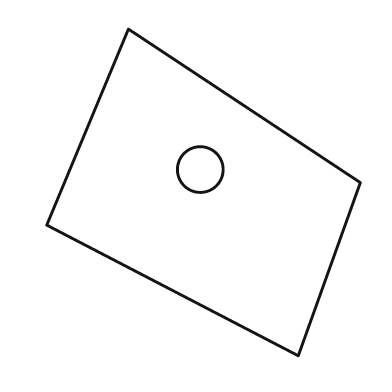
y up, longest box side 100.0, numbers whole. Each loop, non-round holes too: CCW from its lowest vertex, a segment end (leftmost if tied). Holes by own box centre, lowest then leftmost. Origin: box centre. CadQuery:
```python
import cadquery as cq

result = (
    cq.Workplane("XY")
    .moveTo(29.0, -50.0)
    .lineTo(48.0, 3.0)
    .lineTo(-23.0, 50.0)
    .lineTo(-48.0, -10.0)
    .close()
    .moveTo(-1.0, 7.0)
    .circle(7.0)
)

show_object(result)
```